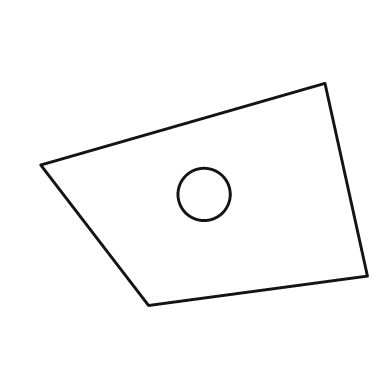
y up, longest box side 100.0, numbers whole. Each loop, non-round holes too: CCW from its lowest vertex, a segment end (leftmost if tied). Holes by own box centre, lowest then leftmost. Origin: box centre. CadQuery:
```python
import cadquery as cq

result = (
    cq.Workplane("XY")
    .moveTo(-17.0, -34.0)
    .lineTo(50.0, -25.0)
    .lineTo(37.0, 34.0)
    .lineTo(-50.0, 9.0)
    .close()
    .moveTo(0.0, 0.0)
    .circle(8.0)
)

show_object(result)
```